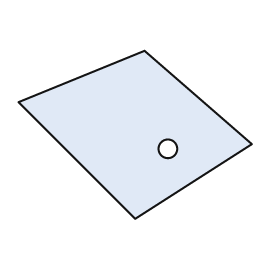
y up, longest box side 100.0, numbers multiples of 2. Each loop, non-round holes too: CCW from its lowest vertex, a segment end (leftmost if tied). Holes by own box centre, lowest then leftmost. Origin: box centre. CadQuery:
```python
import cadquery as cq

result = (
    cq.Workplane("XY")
    .moveTo(0.0, -36.0)
    .lineTo(50.0, -4.0)
    .lineTo(4.0, 36.0)
    .lineTo(-50.0, 14.0)
    .close()
    .moveTo(14.0, -6.0)
    .circle(4.0)
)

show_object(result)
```